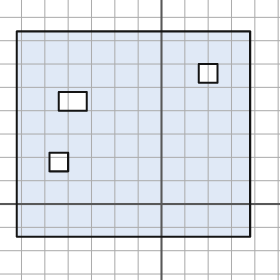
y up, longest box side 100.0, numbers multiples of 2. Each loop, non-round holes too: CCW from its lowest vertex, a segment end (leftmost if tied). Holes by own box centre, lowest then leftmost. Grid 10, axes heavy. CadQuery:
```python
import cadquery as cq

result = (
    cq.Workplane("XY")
    .moveTo(-62.0, -14.0)
    .lineTo(38.0, -14.0)
    .lineTo(38.0, 74.0)
    .lineTo(-62.0, 74.0)
    .close()
    .moveTo(-48.0, 14.0)
    .lineTo(-40.0, 14.0)
    .lineTo(-40.0, 22.0)
    .lineTo(-48.0, 22.0)
    .close()
    .moveTo(-44.0, 40.0)
    .lineTo(-32.0, 40.0)
    .lineTo(-32.0, 48.0)
    .lineTo(-44.0, 48.0)
    .close()
    .moveTo(16.0, 52.0)
    .lineTo(24.0, 52.0)
    .lineTo(24.0, 60.0)
    .lineTo(16.0, 60.0)
    .close()
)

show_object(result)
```